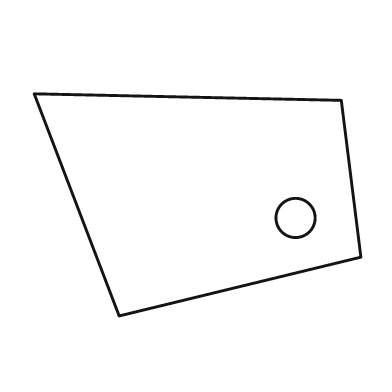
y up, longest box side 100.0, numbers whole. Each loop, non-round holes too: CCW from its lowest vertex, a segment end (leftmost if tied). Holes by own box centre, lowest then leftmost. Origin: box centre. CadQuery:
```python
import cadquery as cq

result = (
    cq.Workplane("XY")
    .moveTo(-24.0, -34.0)
    .lineTo(50.0, -16.0)
    .lineTo(44.0, 32.0)
    .lineTo(-50.0, 34.0)
    .close()
    .moveTo(30.0, -4.0)
    .circle(6.0)
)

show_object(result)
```